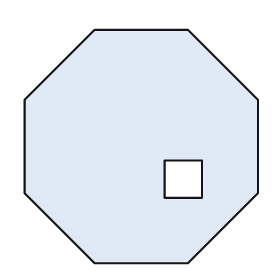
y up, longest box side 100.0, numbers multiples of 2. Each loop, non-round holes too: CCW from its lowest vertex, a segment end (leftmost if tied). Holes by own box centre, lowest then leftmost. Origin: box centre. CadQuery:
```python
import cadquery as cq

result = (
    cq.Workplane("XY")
    .moveTo(-20.0, -50.0)
    .lineTo(20.0, -50.0)
    .lineTo(50.0, -20.0)
    .lineTo(50.0, 20.0)
    .lineTo(20.0, 50.0)
    .lineTo(-20.0, 50.0)
    .lineTo(-50.0, 20.0)
    .lineTo(-50.0, -20.0)
    .close()
    .moveTo(10.0, -22.0)
    .lineTo(26.0, -22.0)
    .lineTo(26.0, -6.0)
    .lineTo(10.0, -6.0)
    .close()
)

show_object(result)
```